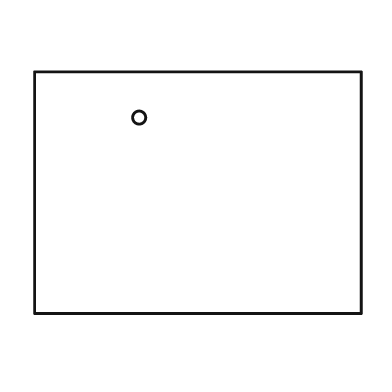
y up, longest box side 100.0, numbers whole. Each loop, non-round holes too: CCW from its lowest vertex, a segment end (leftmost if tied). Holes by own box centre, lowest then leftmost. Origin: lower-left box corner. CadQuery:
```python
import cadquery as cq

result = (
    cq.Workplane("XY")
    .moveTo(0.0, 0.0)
    .lineTo(100.0, 0.0)
    .lineTo(100.0, 74.0)
    .lineTo(0.0, 74.0)
    .close()
    .moveTo(32.0, 60.0)
    .circle(2.0)
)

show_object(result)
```